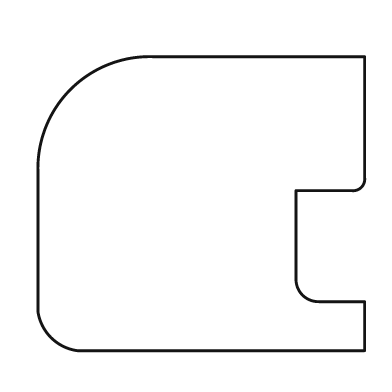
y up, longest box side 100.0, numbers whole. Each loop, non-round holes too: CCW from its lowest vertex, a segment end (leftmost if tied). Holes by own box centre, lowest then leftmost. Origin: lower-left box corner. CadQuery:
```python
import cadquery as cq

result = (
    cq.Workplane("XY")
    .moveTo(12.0, 0.0)
    .lineTo(100.0, 0.0)
    .lineTo(100.0, 15.0)
    .lineTo(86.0, 15.0)
    .threePointArc((81.0, 17.0), (79.0, 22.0))
    .lineTo(79.0, 49.0)
    .lineTo(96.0, 49.0)
    .threePointArc((99.0, 50.0), (100.0, 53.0))
    .lineTo(100.0, 90.0)
    .lineTo(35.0, 90.0)
    .threePointArc((10.0, 80.0), (0.0, 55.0))
    .lineTo(0.0, 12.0)
    .threePointArc((4.0, 4.0), (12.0, 0.0))
    .close()
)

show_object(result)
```